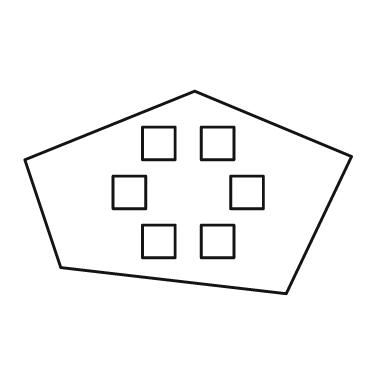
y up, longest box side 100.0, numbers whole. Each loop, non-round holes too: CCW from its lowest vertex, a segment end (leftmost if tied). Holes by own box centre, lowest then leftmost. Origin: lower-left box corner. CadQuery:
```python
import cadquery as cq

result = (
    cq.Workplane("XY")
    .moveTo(80.0, 0.0)
    .lineTo(100.0, 42.0)
    .lineTo(52.0, 62.0)
    .lineTo(0.0, 41.0)
    .lineTo(11.0, 8.0)
    .close()
    .moveTo(36.0, 11.0)
    .lineTo(46.0, 11.0)
    .lineTo(46.0, 21.0)
    .lineTo(36.0, 21.0)
    .close()
    .moveTo(54.0, 11.0)
    .lineTo(64.0, 11.0)
    .lineTo(64.0, 21.0)
    .lineTo(54.0, 21.0)
    .close()
    .moveTo(27.0, 26.0)
    .lineTo(37.0, 26.0)
    .lineTo(37.0, 36.0)
    .lineTo(27.0, 36.0)
    .close()
    .moveTo(63.0, 26.0)
    .lineTo(73.0, 26.0)
    .lineTo(73.0, 36.0)
    .lineTo(63.0, 36.0)
    .close()
    .moveTo(36.0, 41.0)
    .lineTo(46.0, 41.0)
    .lineTo(46.0, 51.0)
    .lineTo(36.0, 51.0)
    .close()
    .moveTo(54.0, 41.0)
    .lineTo(64.0, 41.0)
    .lineTo(64.0, 51.0)
    .lineTo(54.0, 51.0)
    .close()
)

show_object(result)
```